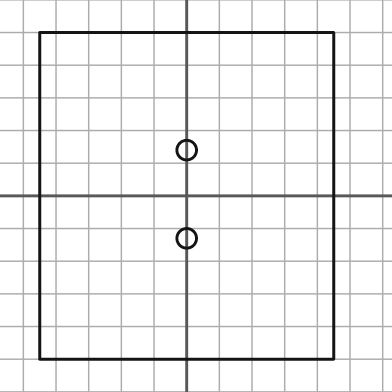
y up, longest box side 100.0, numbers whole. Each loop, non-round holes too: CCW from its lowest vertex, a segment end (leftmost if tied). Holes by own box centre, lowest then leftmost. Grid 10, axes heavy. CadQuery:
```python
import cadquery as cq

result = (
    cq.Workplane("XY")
    .moveTo(-45.0, -50.0)
    .lineTo(45.0, -50.0)
    .lineTo(45.0, 50.0)
    .lineTo(-45.0, 50.0)
    .close()
    .moveTo(0.0, -13.0)
    .circle(3.0)
    .moveTo(0.0, 14.0)
    .circle(3.0)
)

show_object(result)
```